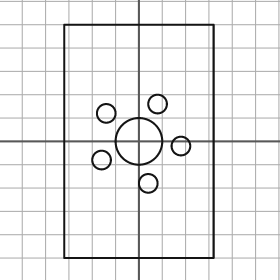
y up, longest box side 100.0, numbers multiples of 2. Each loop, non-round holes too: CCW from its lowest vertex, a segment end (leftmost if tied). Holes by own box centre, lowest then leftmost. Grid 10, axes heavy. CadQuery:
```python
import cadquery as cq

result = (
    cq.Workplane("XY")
    .moveTo(-32.0, -50.0)
    .lineTo(32.0, -50.0)
    .lineTo(32.0, 50.0)
    .lineTo(-32.0, 50.0)
    .close()
    .moveTo(4.0, -18.0)
    .circle(4.0)
    .moveTo(-16.0, -8.0)
    .circle(4.0)
    .moveTo(18.0, -2.0)
    .circle(4.0)
    .moveTo(0.0, 0.0)
    .circle(10.0)
    .moveTo(-14.0, 12.0)
    .circle(4.0)
    .moveTo(8.0, 16.0)
    .circle(4.0)
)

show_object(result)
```